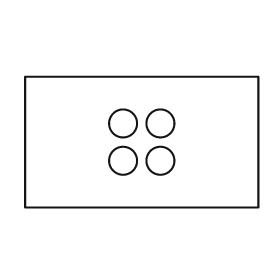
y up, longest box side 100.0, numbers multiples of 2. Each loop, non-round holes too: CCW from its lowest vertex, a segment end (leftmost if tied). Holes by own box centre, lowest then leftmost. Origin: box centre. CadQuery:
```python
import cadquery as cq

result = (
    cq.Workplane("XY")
    .moveTo(-50.0, -28.0)
    .lineTo(50.0, -28.0)
    .lineTo(50.0, 28.0)
    .lineTo(-50.0, 28.0)
    .close()
    .moveTo(-8.0, -8.0)
    .circle(6.0)
    .moveTo(8.0, -8.0)
    .circle(6.0)
    .moveTo(-8.0, 8.0)
    .circle(6.0)
    .moveTo(8.0, 8.0)
    .circle(6.0)
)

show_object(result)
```